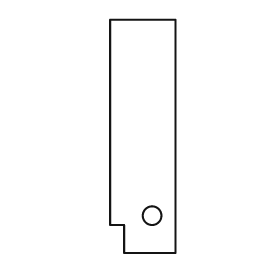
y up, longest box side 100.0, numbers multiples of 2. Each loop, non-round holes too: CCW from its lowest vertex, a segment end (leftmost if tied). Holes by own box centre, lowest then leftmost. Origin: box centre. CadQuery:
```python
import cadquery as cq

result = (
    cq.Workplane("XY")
    .moveTo(-8.0, -50.0)
    .lineTo(14.0, -50.0)
    .lineTo(14.0, 50.0)
    .lineTo(-14.0, 50.0)
    .lineTo(-14.0, -38.0)
    .lineTo(-8.0, -38.0)
    .close()
    .moveTo(4.0, -34.0)
    .circle(4.0)
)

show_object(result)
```